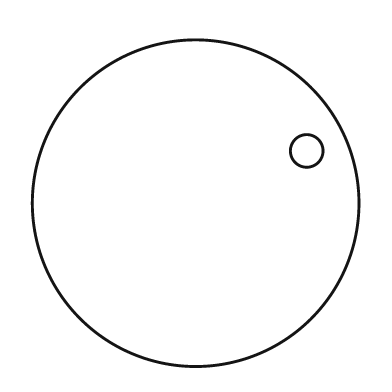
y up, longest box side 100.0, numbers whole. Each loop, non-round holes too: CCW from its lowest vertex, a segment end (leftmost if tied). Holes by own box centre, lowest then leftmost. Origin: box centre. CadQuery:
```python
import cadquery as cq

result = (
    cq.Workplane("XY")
    .moveTo(0.0, 0.0)
    .circle(50.0)
    .moveTo(34.0, 16.0)
    .circle(5.0)
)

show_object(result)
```